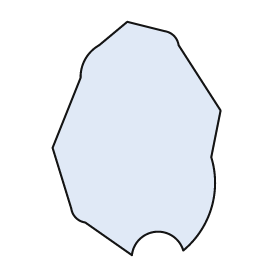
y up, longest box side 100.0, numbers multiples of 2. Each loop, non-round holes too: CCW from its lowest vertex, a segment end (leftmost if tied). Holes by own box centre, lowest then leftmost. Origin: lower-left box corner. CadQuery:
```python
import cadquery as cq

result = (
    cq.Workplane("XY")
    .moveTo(34.0, 0.0)
    .threePointArc((44.0, 10.0), (56.0, 2.0))
    .threePointArc((68.0, 20.0), (68.0, 42.0))
    .lineTo(72.0, 62.0)
    .lineTo(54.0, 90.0)
    .threePointArc((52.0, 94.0), (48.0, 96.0))
    .lineTo(32.0, 100.0)
    .lineTo(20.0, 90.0)
    .threePointArc((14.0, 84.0), (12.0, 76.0))
    .lineTo(0.0, 46.0)
    .lineTo(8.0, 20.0)
    .threePointArc((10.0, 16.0), (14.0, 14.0))
    .close()
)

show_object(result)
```